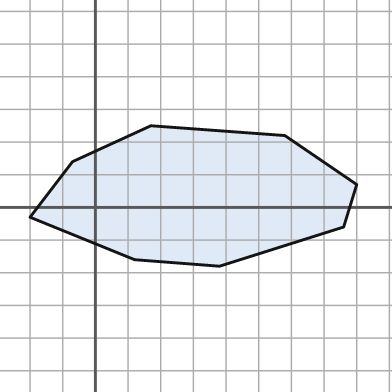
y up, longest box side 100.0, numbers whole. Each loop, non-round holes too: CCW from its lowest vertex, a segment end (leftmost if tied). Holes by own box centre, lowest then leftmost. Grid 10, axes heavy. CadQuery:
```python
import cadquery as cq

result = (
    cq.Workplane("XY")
    .moveTo(38.0, -18.0)
    .lineTo(76.0, -6.0)
    .lineTo(80.0, 7.0)
    .lineTo(58.0, 22.0)
    .lineTo(17.0, 25.0)
    .lineTo(-7.0, 14.0)
    .lineTo(-20.0, -3.0)
    .lineTo(12.0, -16.0)
    .close()
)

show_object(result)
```